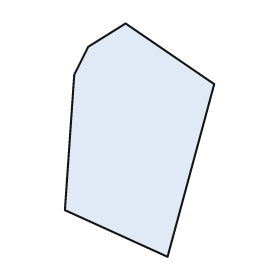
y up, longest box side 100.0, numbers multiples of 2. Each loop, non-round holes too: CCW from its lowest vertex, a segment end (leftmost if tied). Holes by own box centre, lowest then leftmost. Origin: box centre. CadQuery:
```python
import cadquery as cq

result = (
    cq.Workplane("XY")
    .moveTo(12.0, -50.0)
    .lineTo(32.0, 24.0)
    .lineTo(-6.0, 50.0)
    .lineTo(-22.0, 40.0)
    .lineTo(-28.0, 28.0)
    .lineTo(-32.0, -30.0)
    .close()
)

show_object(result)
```